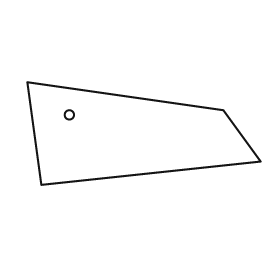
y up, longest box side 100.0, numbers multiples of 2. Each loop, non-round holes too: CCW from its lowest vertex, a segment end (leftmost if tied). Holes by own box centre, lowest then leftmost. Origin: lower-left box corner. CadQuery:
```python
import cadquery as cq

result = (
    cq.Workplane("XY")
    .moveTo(6.0, 0.0)
    .lineTo(100.0, 10.0)
    .lineTo(84.0, 32.0)
    .lineTo(0.0, 44.0)
    .close()
    .moveTo(18.0, 30.0)
    .circle(2.0)
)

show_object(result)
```